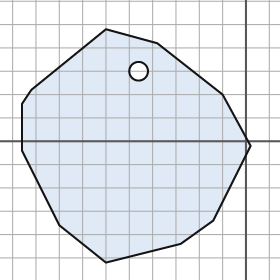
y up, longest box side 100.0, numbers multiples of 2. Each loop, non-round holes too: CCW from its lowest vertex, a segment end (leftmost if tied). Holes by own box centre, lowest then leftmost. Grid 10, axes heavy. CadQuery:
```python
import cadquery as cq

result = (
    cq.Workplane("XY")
    .moveTo(-60.0, -52.0)
    .lineTo(-28.0, -44.0)
    .lineTo(-14.0, -34.0)
    .lineTo(2.0, -2.0)
    .lineTo(-10.0, 20.0)
    .lineTo(-38.0, 42.0)
    .lineTo(-60.0, 48.0)
    .lineTo(-92.0, 22.0)
    .lineTo(-96.0, 16.0)
    .lineTo(-96.0, -4.0)
    .lineTo(-80.0, -36.0)
    .close()
    .moveTo(-46.0, 30.0)
    .circle(4.0)
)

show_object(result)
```